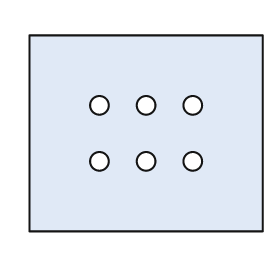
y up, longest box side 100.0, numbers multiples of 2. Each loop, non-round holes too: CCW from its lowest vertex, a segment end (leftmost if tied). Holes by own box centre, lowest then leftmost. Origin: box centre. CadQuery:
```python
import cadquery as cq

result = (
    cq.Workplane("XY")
    .moveTo(-50.0, -42.0)
    .lineTo(50.0, -42.0)
    .lineTo(50.0, 42.0)
    .lineTo(-50.0, 42.0)
    .close()
    .moveTo(-20.0, -12.0)
    .circle(4.0)
    .moveTo(0.0, -12.0)
    .circle(4.0)
    .moveTo(20.0, -12.0)
    .circle(4.0)
    .moveTo(-20.0, 12.0)
    .circle(4.0)
    .moveTo(0.0, 12.0)
    .circle(4.0)
    .moveTo(20.0, 12.0)
    .circle(4.0)
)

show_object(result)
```